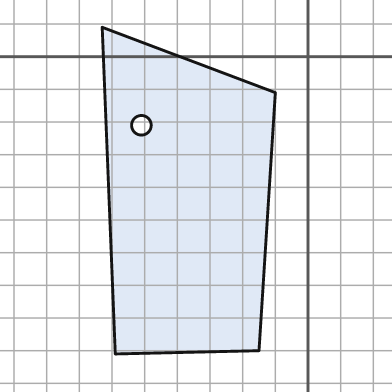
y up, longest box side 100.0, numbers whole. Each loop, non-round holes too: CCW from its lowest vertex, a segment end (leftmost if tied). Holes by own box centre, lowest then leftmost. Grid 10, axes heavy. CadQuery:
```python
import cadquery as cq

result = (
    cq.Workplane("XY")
    .moveTo(-59.0, -91.0)
    .lineTo(-15.0, -90.0)
    .lineTo(-10.0, -11.0)
    .lineTo(-63.0, 9.0)
    .close()
    .moveTo(-51.0, -21.0)
    .circle(3.0)
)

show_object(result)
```